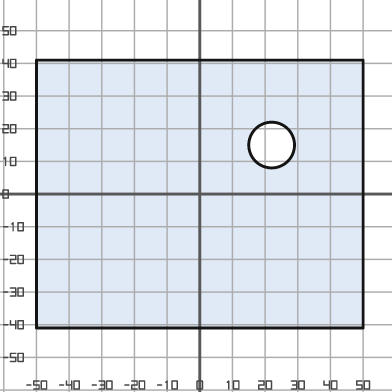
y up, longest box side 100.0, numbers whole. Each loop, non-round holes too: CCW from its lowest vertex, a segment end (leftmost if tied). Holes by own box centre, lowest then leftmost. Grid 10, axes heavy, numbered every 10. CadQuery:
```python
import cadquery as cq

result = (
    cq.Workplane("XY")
    .moveTo(-50.0, -41.0)
    .lineTo(50.0, -41.0)
    .lineTo(50.0, 41.0)
    .lineTo(-50.0, 41.0)
    .close()
    .moveTo(22.0, 15.0)
    .circle(7.0)
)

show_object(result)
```